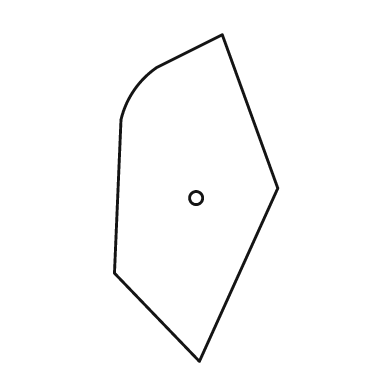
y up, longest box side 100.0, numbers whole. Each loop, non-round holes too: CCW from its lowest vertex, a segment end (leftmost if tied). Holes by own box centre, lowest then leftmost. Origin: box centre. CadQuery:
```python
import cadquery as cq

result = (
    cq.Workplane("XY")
    .moveTo(1.0, -50.0)
    .lineTo(25.0, 3.0)
    .lineTo(8.0, 50.0)
    .lineTo(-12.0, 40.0)
    .threePointArc((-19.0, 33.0), (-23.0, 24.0))
    .lineTo(-25.0, -23.0)
    .close()
    .moveTo(0.0, 0.0)
    .circle(2.0)
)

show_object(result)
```